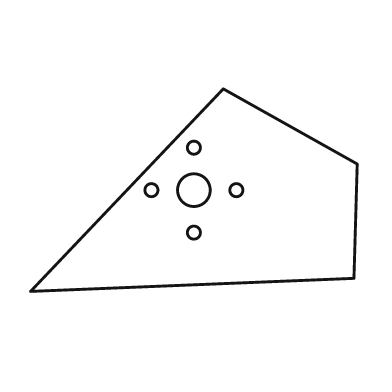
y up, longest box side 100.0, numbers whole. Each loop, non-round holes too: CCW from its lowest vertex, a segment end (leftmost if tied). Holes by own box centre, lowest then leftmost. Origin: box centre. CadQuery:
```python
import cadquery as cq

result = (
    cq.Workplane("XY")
    .moveTo(-50.0, -31.0)
    .lineTo(49.0, -27.0)
    .lineTo(50.0, 8.0)
    .lineTo(9.0, 31.0)
    .close()
    .moveTo(0.0, -13.0)
    .circle(2.0)
    .moveTo(-13.0, 0.0)
    .circle(2.0)
    .moveTo(0.0, 0.0)
    .circle(5.0)
    .moveTo(13.0, 0.0)
    .circle(2.0)
    .moveTo(0.0, 13.0)
    .circle(2.0)
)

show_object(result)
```